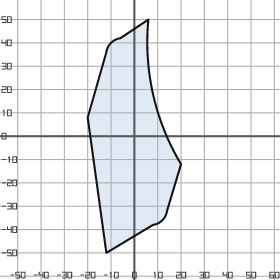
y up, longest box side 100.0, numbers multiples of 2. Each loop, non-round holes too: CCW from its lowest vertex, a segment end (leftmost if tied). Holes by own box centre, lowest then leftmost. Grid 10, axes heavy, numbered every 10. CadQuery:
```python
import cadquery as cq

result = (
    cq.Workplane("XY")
    .moveTo(-12.0, -50.0)
    .lineTo(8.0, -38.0)
    .threePointArc((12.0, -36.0), (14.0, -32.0))
    .lineTo(20.0, -12.0)
    .threePointArc((8.0, 18.0), (6.0, 50.0))
    .lineTo(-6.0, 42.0)
    .threePointArc((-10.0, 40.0), (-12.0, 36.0))
    .lineTo(-20.0, 8.0)
    .close()
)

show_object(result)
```